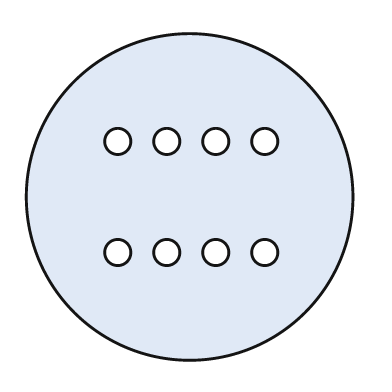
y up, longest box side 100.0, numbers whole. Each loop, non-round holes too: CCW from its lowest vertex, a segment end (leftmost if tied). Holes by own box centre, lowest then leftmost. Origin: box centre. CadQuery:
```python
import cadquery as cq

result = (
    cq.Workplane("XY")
    .moveTo(0.0, 0.0)
    .circle(50.0)
    .moveTo(-22.0, -17.0)
    .circle(4.0)
    .moveTo(-7.0, -17.0)
    .circle(4.0)
    .moveTo(8.0, -17.0)
    .circle(4.0)
    .moveTo(23.0, -17.0)
    .circle(4.0)
    .moveTo(-22.0, 17.0)
    .circle(4.0)
    .moveTo(-7.0, 17.0)
    .circle(4.0)
    .moveTo(8.0, 17.0)
    .circle(4.0)
    .moveTo(23.0, 17.0)
    .circle(4.0)
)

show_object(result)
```